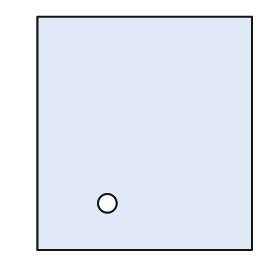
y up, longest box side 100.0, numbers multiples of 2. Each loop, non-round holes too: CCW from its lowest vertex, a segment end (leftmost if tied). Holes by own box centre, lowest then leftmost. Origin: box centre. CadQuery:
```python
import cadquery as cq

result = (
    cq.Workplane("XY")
    .moveTo(-46.0, -50.0)
    .lineTo(46.0, -50.0)
    .lineTo(46.0, 50.0)
    .lineTo(-46.0, 50.0)
    .close()
    .moveTo(-16.0, -30.0)
    .circle(4.0)
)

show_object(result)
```